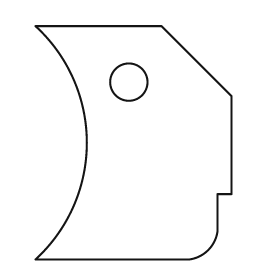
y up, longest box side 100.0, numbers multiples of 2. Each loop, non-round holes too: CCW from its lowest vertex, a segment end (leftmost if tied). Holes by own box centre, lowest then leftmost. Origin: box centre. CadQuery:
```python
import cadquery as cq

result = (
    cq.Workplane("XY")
    .moveTo(-42.0, -50.0)
    .lineTo(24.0, -50.0)
    .threePointArc((32.0, -46.0), (36.0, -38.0))
    .lineTo(36.0, -22.0)
    .lineTo(42.0, -22.0)
    .lineTo(42.0, 20.0)
    .lineTo(12.0, 50.0)
    .lineTo(-42.0, 50.0)
    .threePointArc((-20.0, 0.0), (-42.0, -50.0))
    .close()
    .moveTo(-2.0, 26.0)
    .circle(8.0)
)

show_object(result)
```